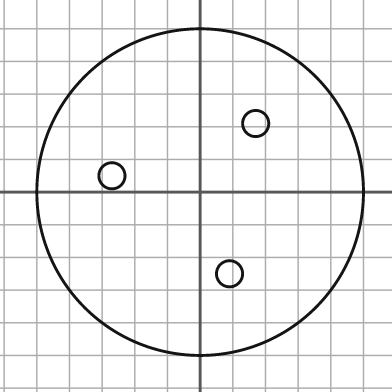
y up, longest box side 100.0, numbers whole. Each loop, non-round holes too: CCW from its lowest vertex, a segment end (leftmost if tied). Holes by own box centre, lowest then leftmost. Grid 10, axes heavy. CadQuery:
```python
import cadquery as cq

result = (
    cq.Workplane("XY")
    .moveTo(0.0, 0.0)
    .circle(50.0)
    .moveTo(9.0, -25.0)
    .circle(4.0)
    .moveTo(-27.0, 5.0)
    .circle(4.0)
    .moveTo(17.0, 21.0)
    .circle(4.0)
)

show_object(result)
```